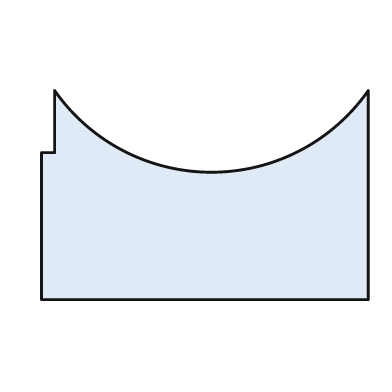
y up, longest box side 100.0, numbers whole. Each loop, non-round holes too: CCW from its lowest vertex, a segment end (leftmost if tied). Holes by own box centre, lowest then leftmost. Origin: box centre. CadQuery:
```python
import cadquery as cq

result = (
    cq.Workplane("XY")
    .moveTo(-50.0, -32.0)
    .lineTo(50.0, -32.0)
    .lineTo(50.0, 32.0)
    .threePointArc((2.0, 7.0), (-46.0, 32.0))
    .lineTo(-46.0, 13.0)
    .lineTo(-50.0, 13.0)
    .close()
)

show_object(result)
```